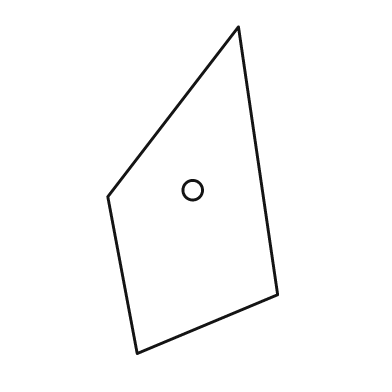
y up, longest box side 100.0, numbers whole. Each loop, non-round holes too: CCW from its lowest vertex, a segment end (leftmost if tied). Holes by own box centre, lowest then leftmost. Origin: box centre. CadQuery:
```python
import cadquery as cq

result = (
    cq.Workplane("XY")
    .moveTo(-17.0, -50.0)
    .lineTo(26.0, -32.0)
    .lineTo(14.0, 50.0)
    .lineTo(-26.0, -2.0)
    .close()
    .moveTo(0.0, 0.0)
    .circle(3.0)
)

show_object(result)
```